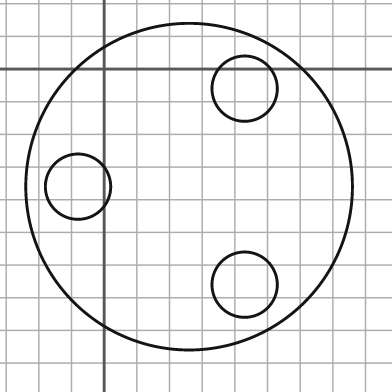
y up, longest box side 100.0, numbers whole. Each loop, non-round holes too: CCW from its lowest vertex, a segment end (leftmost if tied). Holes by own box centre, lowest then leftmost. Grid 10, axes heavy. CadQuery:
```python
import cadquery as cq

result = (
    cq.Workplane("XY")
    .moveTo(26.0, -36.0)
    .circle(50.0)
    .moveTo(43.0, -66.0)
    .circle(10.0)
    .moveTo(-8.0, -36.0)
    .circle(10.0)
    .moveTo(43.0, -6.0)
    .circle(10.0)
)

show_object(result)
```